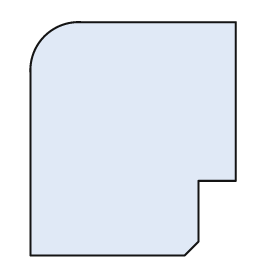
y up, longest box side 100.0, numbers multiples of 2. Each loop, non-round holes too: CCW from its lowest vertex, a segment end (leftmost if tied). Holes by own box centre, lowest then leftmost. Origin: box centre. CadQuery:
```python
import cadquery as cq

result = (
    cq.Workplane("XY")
    .moveTo(-44.0, -50.0)
    .lineTo(22.0, -50.0)
    .lineTo(28.0, -44.0)
    .lineTo(28.0, -18.0)
    .lineTo(44.0, -18.0)
    .lineTo(44.0, 50.0)
    .lineTo(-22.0, 50.0)
    .threePointArc((-38.0, 44.0), (-44.0, 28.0))
    .close()
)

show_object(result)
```